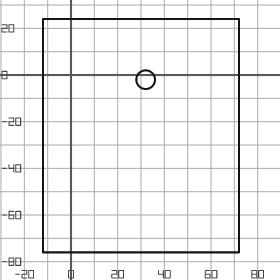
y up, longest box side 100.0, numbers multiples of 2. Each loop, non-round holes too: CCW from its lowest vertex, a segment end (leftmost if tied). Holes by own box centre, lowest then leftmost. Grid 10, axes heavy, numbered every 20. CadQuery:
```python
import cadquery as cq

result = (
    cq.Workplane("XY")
    .moveTo(-12.0, -76.0)
    .lineTo(72.0, -76.0)
    .lineTo(72.0, 24.0)
    .lineTo(-12.0, 24.0)
    .close()
    .moveTo(32.0, -2.0)
    .circle(4.0)
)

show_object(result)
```